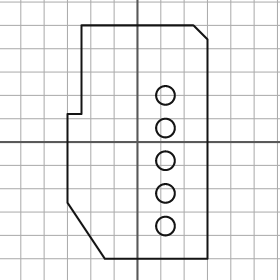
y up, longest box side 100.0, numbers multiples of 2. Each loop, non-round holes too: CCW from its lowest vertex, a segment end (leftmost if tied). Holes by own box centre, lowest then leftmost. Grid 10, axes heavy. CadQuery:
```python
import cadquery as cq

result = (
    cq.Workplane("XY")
    .moveTo(-14.0, -50.0)
    .lineTo(30.0, -50.0)
    .lineTo(30.0, 44.0)
    .lineTo(24.0, 50.0)
    .lineTo(-24.0, 50.0)
    .lineTo(-24.0, 12.0)
    .lineTo(-30.0, 12.0)
    .lineTo(-30.0, -26.0)
    .close()
    .moveTo(12.0, -36.0)
    .circle(4.0)
    .moveTo(12.0, -22.0)
    .circle(4.0)
    .moveTo(12.0, -8.0)
    .circle(4.0)
    .moveTo(12.0, 6.0)
    .circle(4.0)
    .moveTo(12.0, 20.0)
    .circle(4.0)
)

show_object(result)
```